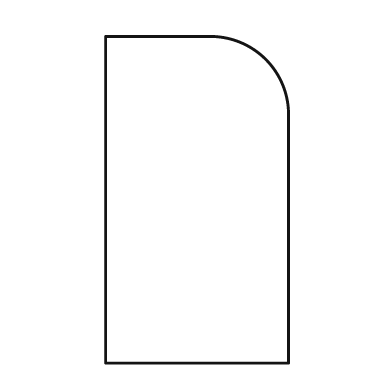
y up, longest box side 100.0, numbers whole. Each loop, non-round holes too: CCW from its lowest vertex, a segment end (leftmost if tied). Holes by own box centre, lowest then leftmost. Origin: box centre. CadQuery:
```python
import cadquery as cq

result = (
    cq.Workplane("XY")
    .moveTo(-28.0, -50.0)
    .lineTo(28.0, -50.0)
    .lineTo(28.0, 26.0)
    .threePointArc((21.0, 43.0), (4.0, 50.0))
    .lineTo(-28.0, 50.0)
    .close()
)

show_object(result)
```